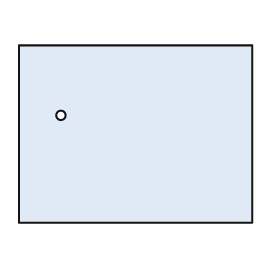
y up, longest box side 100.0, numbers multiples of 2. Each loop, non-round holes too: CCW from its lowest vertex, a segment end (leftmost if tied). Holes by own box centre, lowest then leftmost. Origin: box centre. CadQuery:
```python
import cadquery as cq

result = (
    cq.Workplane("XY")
    .moveTo(-50.0, -38.0)
    .lineTo(50.0, -38.0)
    .lineTo(50.0, 38.0)
    .lineTo(-50.0, 38.0)
    .close()
    .moveTo(-32.0, 8.0)
    .circle(2.0)
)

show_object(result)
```